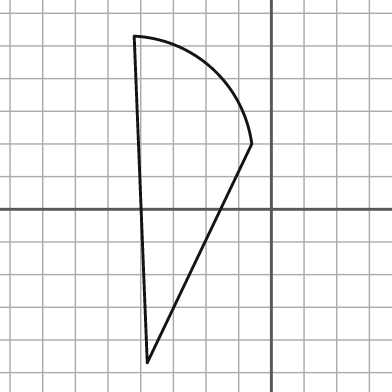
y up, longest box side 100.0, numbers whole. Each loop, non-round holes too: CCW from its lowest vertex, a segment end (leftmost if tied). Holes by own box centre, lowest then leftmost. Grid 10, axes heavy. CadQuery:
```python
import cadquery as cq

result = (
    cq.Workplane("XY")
    .moveTo(-38.0, -47.0)
    .lineTo(-6.0, 20.0)
    .threePointArc((-18.0, 43.0), (-42.0, 53.0))
    .close()
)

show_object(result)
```